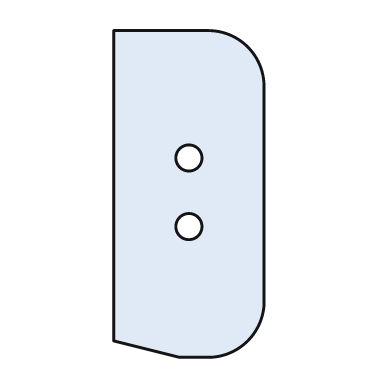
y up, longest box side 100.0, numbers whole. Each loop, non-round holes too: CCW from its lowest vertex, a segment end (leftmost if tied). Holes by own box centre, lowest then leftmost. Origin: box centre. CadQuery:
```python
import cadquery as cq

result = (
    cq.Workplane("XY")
    .moveTo(-3.0, -50.0)
    .lineTo(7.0, -50.0)
    .threePointArc((18.0, -45.0), (23.0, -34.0))
    .lineTo(23.0, 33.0)
    .threePointArc((18.0, 45.0), (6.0, 50.0))
    .lineTo(-23.0, 50.0)
    .lineTo(-23.0, -45.0)
    .close()
    .moveTo(0.0, -10.0)
    .circle(4.0)
    .moveTo(0.0, 11.0)
    .circle(4.0)
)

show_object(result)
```